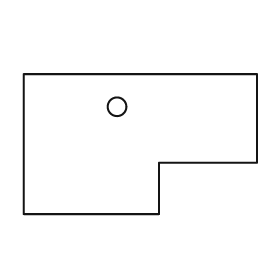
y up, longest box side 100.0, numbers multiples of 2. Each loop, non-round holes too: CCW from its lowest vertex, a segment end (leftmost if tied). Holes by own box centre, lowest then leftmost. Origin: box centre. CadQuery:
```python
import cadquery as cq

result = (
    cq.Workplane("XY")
    .moveTo(-50.0, -30.0)
    .lineTo(8.0, -30.0)
    .lineTo(8.0, -8.0)
    .lineTo(50.0, -8.0)
    .lineTo(50.0, 30.0)
    .lineTo(-50.0, 30.0)
    .close()
    .moveTo(-10.0, 16.0)
    .circle(4.0)
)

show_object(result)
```